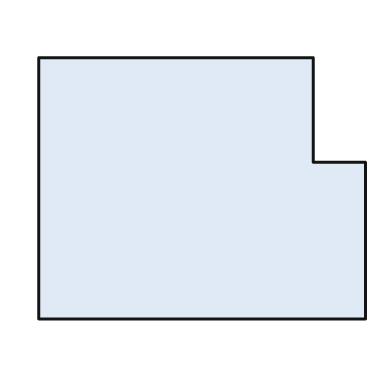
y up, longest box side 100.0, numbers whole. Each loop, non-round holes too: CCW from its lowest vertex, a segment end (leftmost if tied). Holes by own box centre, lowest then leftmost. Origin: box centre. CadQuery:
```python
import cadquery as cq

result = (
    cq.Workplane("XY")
    .moveTo(-50.0, -40.0)
    .lineTo(50.0, -40.0)
    .lineTo(50.0, 8.0)
    .lineTo(34.0, 8.0)
    .lineTo(34.0, 40.0)
    .lineTo(-50.0, 40.0)
    .close()
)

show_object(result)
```